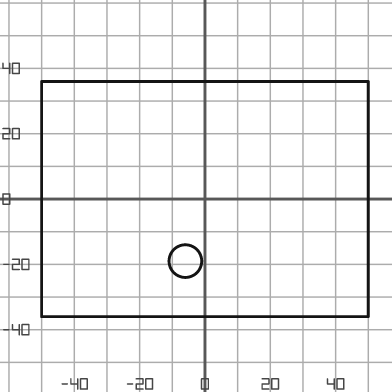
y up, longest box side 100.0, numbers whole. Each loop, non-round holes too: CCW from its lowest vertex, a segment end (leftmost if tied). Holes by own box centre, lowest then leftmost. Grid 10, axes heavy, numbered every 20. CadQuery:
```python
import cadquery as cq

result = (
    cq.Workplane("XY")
    .moveTo(-50.0, -36.0)
    .lineTo(50.0, -36.0)
    .lineTo(50.0, 36.0)
    .lineTo(-50.0, 36.0)
    .close()
    .moveTo(-6.0, -19.0)
    .circle(5.0)
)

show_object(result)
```